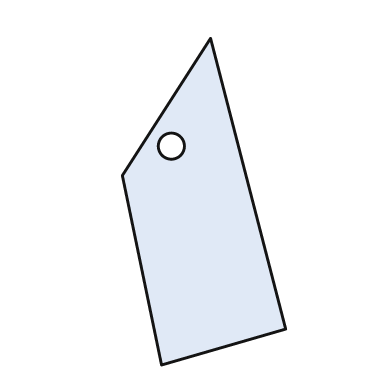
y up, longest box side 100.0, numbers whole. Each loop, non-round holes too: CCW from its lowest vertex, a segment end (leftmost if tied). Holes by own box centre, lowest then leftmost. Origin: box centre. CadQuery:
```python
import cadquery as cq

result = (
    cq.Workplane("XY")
    .moveTo(-13.0, -50.0)
    .lineTo(25.0, -39.0)
    .lineTo(2.0, 50.0)
    .lineTo(-25.0, 8.0)
    .close()
    .moveTo(-10.0, 17.0)
    .circle(4.0)
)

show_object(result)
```